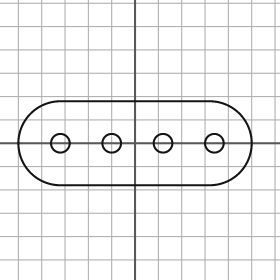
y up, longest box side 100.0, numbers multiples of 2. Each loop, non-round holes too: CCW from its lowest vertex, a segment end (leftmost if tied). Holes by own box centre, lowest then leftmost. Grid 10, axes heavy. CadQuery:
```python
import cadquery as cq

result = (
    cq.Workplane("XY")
    .moveTo(-32.0, -18.0)
    .lineTo(32.0, -18.0)
    .threePointArc((50.0, 0.0), (32.0, 18.0))
    .lineTo(-32.0, 18.0)
    .threePointArc((-50.0, 0.0), (-32.0, -18.0))
    .close()
    .moveTo(-32.0, 0.0)
    .circle(4.0)
    .moveTo(-10.0, 0.0)
    .circle(4.0)
    .moveTo(12.0, 0.0)
    .circle(4.0)
    .moveTo(34.0, 0.0)
    .circle(4.0)
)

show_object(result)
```